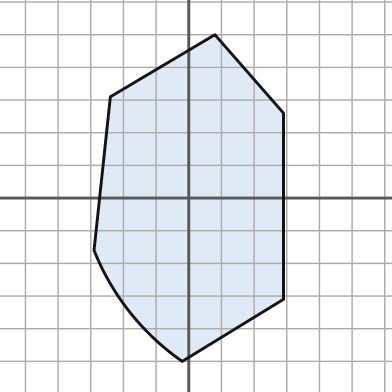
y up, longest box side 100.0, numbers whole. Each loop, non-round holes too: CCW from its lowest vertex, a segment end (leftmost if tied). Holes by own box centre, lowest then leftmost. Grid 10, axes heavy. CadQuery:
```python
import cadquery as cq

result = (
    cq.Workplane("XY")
    .moveTo(-2.0, -50.0)
    .lineTo(29.0, -31.0)
    .lineTo(29.0, 26.0)
    .lineTo(8.0, 50.0)
    .lineTo(-24.0, 31.0)
    .lineTo(-29.0, -16.0)
    .threePointArc((-18.0, -35.0), (-2.0, -50.0))
    .close()
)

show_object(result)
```